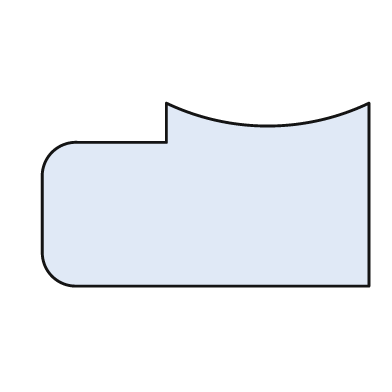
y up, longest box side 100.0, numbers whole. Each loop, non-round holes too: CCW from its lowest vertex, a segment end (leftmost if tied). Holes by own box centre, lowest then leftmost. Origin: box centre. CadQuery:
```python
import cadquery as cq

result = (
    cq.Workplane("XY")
    .moveTo(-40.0, -28.0)
    .lineTo(50.0, -28.0)
    .lineTo(50.0, 28.0)
    .threePointArc((19.0, 21.0), (-12.0, 28.0))
    .lineTo(-12.0, 16.0)
    .lineTo(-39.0, 16.0)
    .threePointArc((-47.0, 13.0), (-50.0, 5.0))
    .lineTo(-50.0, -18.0)
    .threePointArc((-47.0, -25.0), (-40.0, -28.0))
    .close()
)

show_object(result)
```